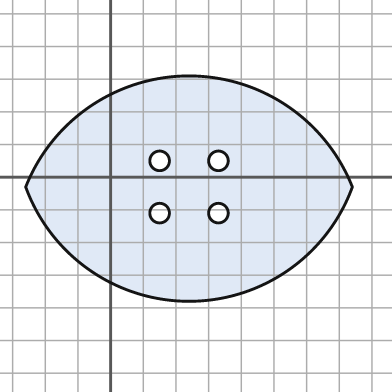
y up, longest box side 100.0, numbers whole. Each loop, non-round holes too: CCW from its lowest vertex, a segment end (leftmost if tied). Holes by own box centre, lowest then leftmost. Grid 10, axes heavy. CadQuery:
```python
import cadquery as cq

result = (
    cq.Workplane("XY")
    .moveTo(-26.0, -3.0)
    .threePointArc((24.0, -38.0), (74.0, -3.0))
    .threePointArc((24.0, 31.0), (-26.0, -3.0))
    .close()
    .moveTo(15.0, -11.0)
    .circle(3.0)
    .moveTo(33.0, -11.0)
    .circle(3.0)
    .moveTo(15.0, 5.0)
    .circle(3.0)
    .moveTo(33.0, 5.0)
    .circle(3.0)
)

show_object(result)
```